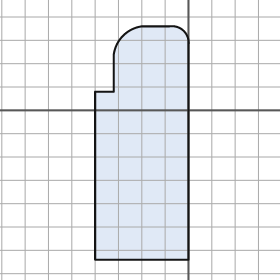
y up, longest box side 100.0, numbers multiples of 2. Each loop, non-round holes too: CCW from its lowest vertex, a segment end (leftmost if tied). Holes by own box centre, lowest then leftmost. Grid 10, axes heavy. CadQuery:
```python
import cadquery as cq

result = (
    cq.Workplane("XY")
    .moveTo(-40.0, -64.0)
    .lineTo(0.0, -64.0)
    .lineTo(0.0, 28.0)
    .threePointArc((-2.0, 34.0), (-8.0, 36.0))
    .lineTo(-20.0, 36.0)
    .threePointArc((-28.0, 32.0), (-32.0, 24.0))
    .lineTo(-32.0, 8.0)
    .lineTo(-40.0, 8.0)
    .close()
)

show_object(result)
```